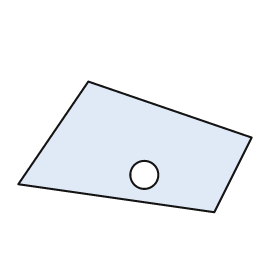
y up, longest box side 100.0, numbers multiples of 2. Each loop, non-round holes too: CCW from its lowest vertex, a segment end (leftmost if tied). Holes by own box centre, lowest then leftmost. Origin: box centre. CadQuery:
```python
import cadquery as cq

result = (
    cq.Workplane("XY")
    .moveTo(34.0, -28.0)
    .lineTo(50.0, 4.0)
    .lineTo(-20.0, 28.0)
    .lineTo(-50.0, -16.0)
    .close()
    .moveTo(4.0, -12.0)
    .circle(6.0)
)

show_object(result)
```